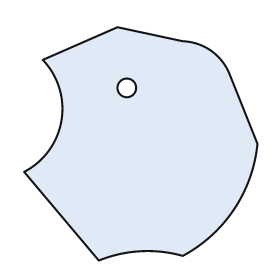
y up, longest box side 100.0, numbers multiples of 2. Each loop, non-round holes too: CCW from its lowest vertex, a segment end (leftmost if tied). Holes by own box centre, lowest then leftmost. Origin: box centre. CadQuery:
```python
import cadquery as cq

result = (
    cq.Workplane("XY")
    .moveTo(-18.0, -50.0)
    .threePointArc((0.0, -46.0), (18.0, -48.0))
    .threePointArc((40.0, -28.0), (50.0, 0.0))
    .lineTo(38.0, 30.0)
    .threePointArc((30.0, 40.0), (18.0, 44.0))
    .lineTo(-10.0, 50.0)
    .lineTo(-42.0, 36.0)
    .threePointArc((-34.0, 10.0), (-50.0, -12.0))
    .close()
    .moveTo(-6.0, 24.0)
    .circle(4.0)
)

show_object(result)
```